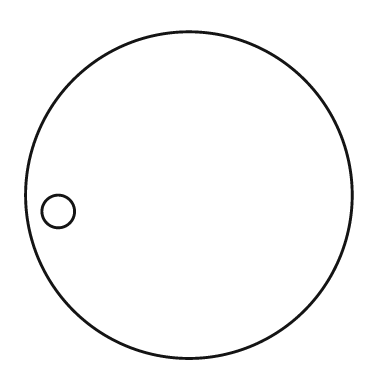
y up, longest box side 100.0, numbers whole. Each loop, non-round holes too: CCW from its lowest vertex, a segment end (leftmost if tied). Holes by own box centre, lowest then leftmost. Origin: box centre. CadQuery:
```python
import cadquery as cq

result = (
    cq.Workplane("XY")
    .moveTo(0.0, 0.0)
    .circle(50.0)
    .moveTo(-40.0, -5.0)
    .circle(5.0)
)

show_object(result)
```